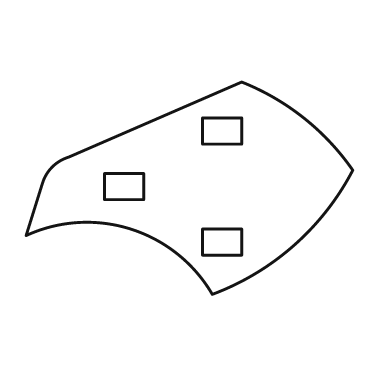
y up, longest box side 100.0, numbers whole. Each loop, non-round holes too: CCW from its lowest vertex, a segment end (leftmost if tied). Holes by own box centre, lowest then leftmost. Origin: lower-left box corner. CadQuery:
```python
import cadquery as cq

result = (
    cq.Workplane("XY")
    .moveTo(57.0, 0.0)
    .threePointArc((82.0, 15.0), (100.0, 38.0))
    .threePointArc((85.0, 54.0), (66.0, 65.0))
    .lineTo(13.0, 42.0)
    .threePointArc((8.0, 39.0), (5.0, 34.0))
    .lineTo(0.0, 18.0)
    .threePointArc((32.0, 20.0), (57.0, 0.0))
    .close()
    .moveTo(54.0, 12.0)
    .lineTo(66.0, 12.0)
    .lineTo(66.0, 20.0)
    .lineTo(54.0, 20.0)
    .close()
    .moveTo(24.0, 29.0)
    .lineTo(36.0, 29.0)
    .lineTo(36.0, 37.0)
    .lineTo(24.0, 37.0)
    .close()
    .moveTo(54.0, 46.0)
    .lineTo(66.0, 46.0)
    .lineTo(66.0, 54.0)
    .lineTo(54.0, 54.0)
    .close()
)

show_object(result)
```